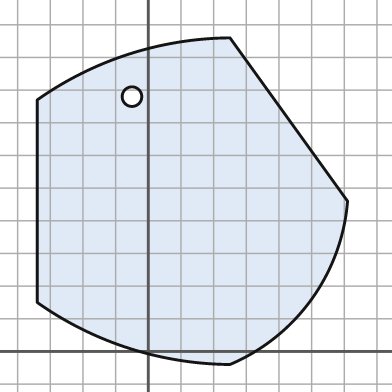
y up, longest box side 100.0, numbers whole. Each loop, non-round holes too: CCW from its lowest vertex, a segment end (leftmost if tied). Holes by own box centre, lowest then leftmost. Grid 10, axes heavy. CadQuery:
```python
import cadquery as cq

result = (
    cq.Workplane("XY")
    .moveTo(25.0, -4.0)
    .threePointArc((50.0, 16.0), (61.0, 46.0))
    .lineTo(25.0, 96.0)
    .threePointArc((-6.0, 91.0), (-34.0, 77.0))
    .lineTo(-34.0, 15.0)
    .threePointArc((-6.0, 1.0), (25.0, -4.0))
    .close()
    .moveTo(-5.0, 78.0)
    .circle(3.0)
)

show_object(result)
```